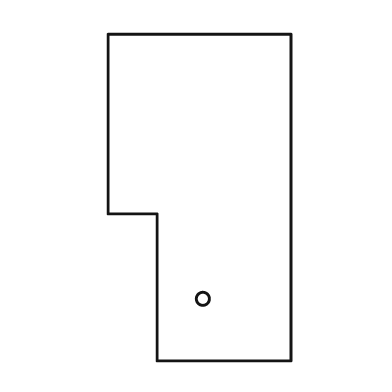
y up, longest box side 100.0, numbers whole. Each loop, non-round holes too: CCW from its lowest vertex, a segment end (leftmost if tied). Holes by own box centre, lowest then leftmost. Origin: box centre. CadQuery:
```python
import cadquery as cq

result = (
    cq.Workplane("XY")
    .moveTo(-13.0, -50.0)
    .lineTo(28.0, -50.0)
    .lineTo(28.0, 50.0)
    .lineTo(-28.0, 50.0)
    .lineTo(-28.0, -5.0)
    .lineTo(-13.0, -5.0)
    .close()
    .moveTo(1.0, -31.0)
    .circle(2.0)
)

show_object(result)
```